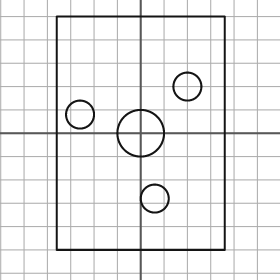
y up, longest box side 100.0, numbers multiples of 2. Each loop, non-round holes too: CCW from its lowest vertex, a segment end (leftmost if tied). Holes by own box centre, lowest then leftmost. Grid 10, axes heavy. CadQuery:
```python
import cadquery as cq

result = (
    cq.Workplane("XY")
    .moveTo(-36.0, -50.0)
    .lineTo(36.0, -50.0)
    .lineTo(36.0, 50.0)
    .lineTo(-36.0, 50.0)
    .close()
    .moveTo(6.0, -28.0)
    .circle(6.0)
    .moveTo(0.0, 0.0)
    .circle(10.0)
    .moveTo(-26.0, 8.0)
    .circle(6.0)
    .moveTo(20.0, 20.0)
    .circle(6.0)
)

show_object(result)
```